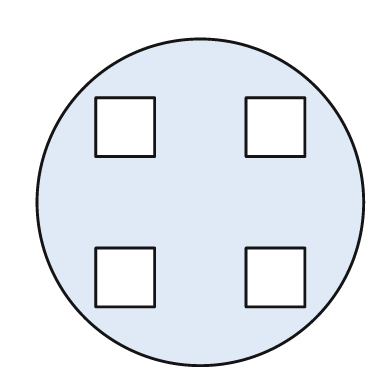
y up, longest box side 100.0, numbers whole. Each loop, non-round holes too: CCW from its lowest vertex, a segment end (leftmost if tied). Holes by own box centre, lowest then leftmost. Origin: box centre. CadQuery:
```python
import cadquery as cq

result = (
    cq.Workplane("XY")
    .moveTo(0.0, 0.0)
    .circle(50.0)
    .moveTo(-32.0, -32.0)
    .lineTo(-14.0, -32.0)
    .lineTo(-14.0, -14.0)
    .lineTo(-32.0, -14.0)
    .close()
    .moveTo(14.0, -32.0)
    .lineTo(32.0, -32.0)
    .lineTo(32.0, -14.0)
    .lineTo(14.0, -14.0)
    .close()
    .moveTo(-32.0, 14.0)
    .lineTo(-14.0, 14.0)
    .lineTo(-14.0, 32.0)
    .lineTo(-32.0, 32.0)
    .close()
    .moveTo(14.0, 14.0)
    .lineTo(32.0, 14.0)
    .lineTo(32.0, 32.0)
    .lineTo(14.0, 32.0)
    .close()
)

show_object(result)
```